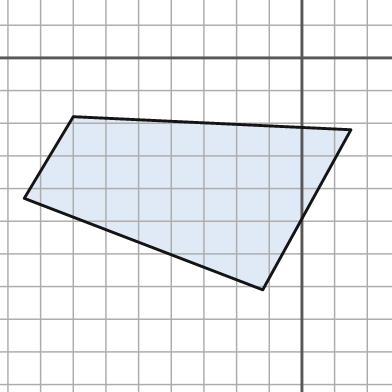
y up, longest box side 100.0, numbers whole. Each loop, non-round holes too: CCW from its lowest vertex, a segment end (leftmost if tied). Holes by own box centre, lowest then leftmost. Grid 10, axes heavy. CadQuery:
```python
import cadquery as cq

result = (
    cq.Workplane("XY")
    .moveTo(-12.0, -71.0)
    .lineTo(15.0, -22.0)
    .lineTo(-70.0, -18.0)
    .lineTo(-85.0, -43.0)
    .close()
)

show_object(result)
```